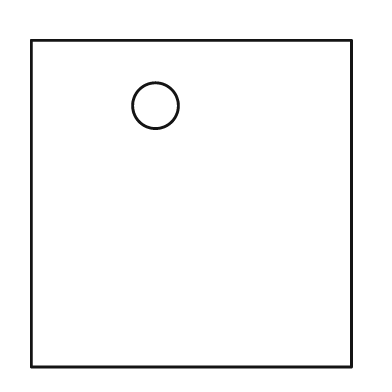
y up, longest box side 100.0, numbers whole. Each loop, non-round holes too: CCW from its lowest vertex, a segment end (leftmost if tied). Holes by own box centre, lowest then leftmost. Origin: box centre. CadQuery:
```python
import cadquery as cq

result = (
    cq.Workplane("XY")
    .moveTo(-49.0, -50.0)
    .lineTo(49.0, -50.0)
    .lineTo(49.0, 50.0)
    .lineTo(-49.0, 50.0)
    .close()
    .moveTo(-11.0, 30.0)
    .circle(7.0)
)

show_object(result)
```